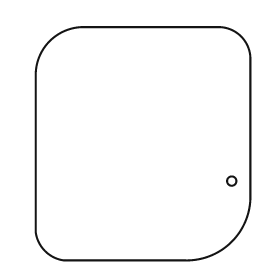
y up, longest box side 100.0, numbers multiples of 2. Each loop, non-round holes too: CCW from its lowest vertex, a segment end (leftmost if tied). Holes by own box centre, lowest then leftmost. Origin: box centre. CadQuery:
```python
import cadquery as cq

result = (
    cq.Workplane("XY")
    .moveTo(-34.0, -50.0)
    .lineTo(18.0, -50.0)
    .threePointArc((38.0, -42.0), (46.0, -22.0))
    .lineTo(46.0, 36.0)
    .threePointArc((42.0, 46.0), (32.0, 50.0))
    .lineTo(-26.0, 50.0)
    .threePointArc((-40.0, 44.0), (-46.0, 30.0))
    .lineTo(-46.0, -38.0)
    .threePointArc((-42.0, -46.0), (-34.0, -50.0))
    .close()
    .moveTo(38.0, -16.0)
    .circle(2.0)
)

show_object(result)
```